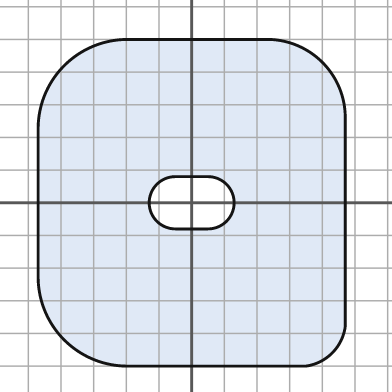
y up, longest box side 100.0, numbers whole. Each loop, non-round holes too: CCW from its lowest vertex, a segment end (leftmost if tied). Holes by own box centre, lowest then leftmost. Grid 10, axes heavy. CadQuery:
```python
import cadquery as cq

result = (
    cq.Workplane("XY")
    .moveTo(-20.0, -50.0)
    .lineTo(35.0, -50.0)
    .threePointArc((43.0, -46.0), (47.0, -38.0))
    .lineTo(47.0, 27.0)
    .threePointArc((40.0, 43.0), (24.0, 50.0))
    .lineTo(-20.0, 50.0)
    .threePointArc((-39.0, 42.0), (-47.0, 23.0))
    .lineTo(-47.0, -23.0)
    .threePointArc((-39.0, -42.0), (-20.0, -50.0))
    .close()
    .moveTo(-5.0, -8.0)
    .lineTo(5.0, -8.0)
    .threePointArc((13.0, 0.0), (5.0, 8.0))
    .lineTo(-5.0, 8.0)
    .threePointArc((-13.0, 0.0), (-5.0, -8.0))
    .close()
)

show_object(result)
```